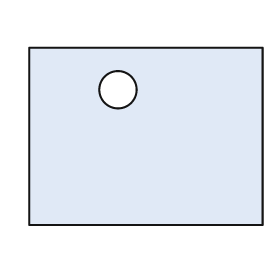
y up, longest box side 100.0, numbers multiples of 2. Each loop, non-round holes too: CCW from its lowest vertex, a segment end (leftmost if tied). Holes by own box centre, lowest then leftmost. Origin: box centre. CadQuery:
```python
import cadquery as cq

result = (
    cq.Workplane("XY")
    .moveTo(-50.0, -38.0)
    .lineTo(50.0, -38.0)
    .lineTo(50.0, 38.0)
    .lineTo(-50.0, 38.0)
    .close()
    .moveTo(-12.0, 20.0)
    .circle(8.0)
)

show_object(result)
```